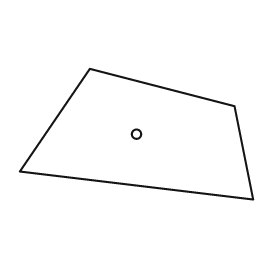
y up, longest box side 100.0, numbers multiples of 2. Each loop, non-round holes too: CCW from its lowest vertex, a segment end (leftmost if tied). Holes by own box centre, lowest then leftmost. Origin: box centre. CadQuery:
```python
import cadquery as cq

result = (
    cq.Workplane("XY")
    .moveTo(50.0, -28.0)
    .lineTo(42.0, 12.0)
    .lineTo(-20.0, 28.0)
    .lineTo(-50.0, -16.0)
    .close()
    .moveTo(0.0, 0.0)
    .circle(2.0)
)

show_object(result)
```